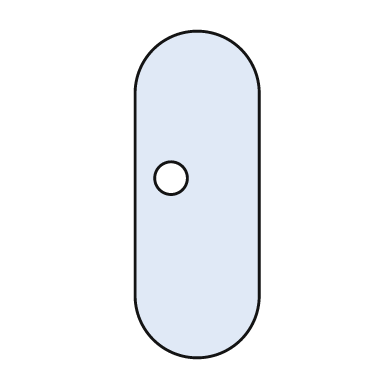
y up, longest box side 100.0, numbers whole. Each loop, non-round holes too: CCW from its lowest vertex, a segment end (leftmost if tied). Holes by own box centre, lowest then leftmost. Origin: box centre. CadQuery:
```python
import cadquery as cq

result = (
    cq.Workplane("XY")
    .moveTo(-19.0, -31.0)
    .threePointArc((0.0, -50.0), (19.0, -31.0))
    .lineTo(19.0, 31.0)
    .threePointArc((0.0, 50.0), (-19.0, 31.0))
    .close()
    .moveTo(-8.0, 5.0)
    .circle(5.0)
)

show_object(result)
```